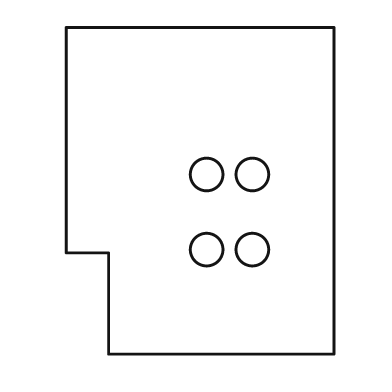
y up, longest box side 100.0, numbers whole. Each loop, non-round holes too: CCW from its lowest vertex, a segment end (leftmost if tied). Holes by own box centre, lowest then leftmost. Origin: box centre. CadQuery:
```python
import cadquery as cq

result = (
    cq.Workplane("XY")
    .moveTo(-28.0, -50.0)
    .lineTo(41.0, -50.0)
    .lineTo(41.0, 50.0)
    .lineTo(-41.0, 50.0)
    .lineTo(-41.0, -19.0)
    .lineTo(-28.0, -19.0)
    .close()
    .moveTo(2.0, -18.0)
    .circle(5.0)
    .moveTo(16.0, -18.0)
    .circle(5.0)
    .moveTo(2.0, 5.0)
    .circle(5.0)
    .moveTo(16.0, 5.0)
    .circle(5.0)
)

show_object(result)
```